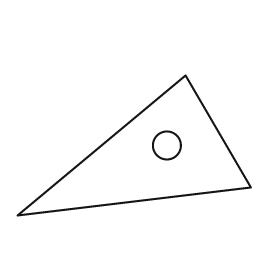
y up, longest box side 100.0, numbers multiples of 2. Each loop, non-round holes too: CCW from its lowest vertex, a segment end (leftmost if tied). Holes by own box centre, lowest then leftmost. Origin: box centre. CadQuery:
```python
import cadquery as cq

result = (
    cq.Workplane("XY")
    .moveTo(-50.0, -30.0)
    .lineTo(50.0, -18.0)
    .lineTo(22.0, 30.0)
    .close()
    .moveTo(14.0, 0.0)
    .circle(6.0)
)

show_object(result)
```